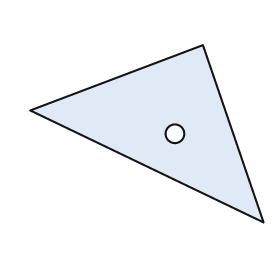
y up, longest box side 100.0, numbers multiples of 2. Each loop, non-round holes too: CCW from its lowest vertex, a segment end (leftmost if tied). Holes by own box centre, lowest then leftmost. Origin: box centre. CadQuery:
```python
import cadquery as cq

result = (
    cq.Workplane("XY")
    .moveTo(50.0, -38.0)
    .lineTo(24.0, 38.0)
    .lineTo(-50.0, 10.0)
    .close()
    .moveTo(12.0, 0.0)
    .circle(4.0)
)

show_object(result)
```